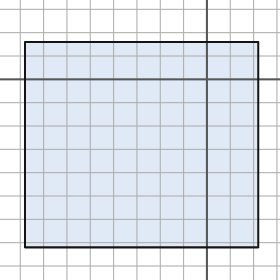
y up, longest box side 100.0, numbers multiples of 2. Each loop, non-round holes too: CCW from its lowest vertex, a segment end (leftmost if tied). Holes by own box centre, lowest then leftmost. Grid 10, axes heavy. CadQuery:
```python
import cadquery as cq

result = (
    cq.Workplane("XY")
    .moveTo(-78.0, -72.0)
    .lineTo(22.0, -72.0)
    .lineTo(22.0, 16.0)
    .lineTo(-78.0, 16.0)
    .close()
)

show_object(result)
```